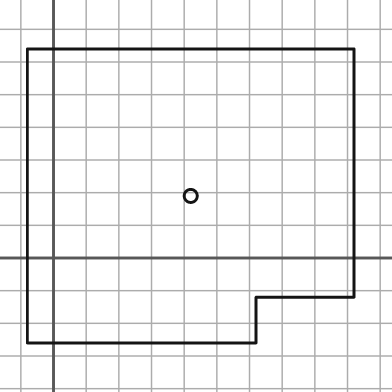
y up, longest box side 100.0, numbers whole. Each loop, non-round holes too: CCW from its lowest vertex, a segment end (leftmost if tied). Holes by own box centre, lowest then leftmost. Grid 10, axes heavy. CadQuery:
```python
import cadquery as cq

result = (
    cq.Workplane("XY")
    .moveTo(-8.0, -26.0)
    .lineTo(62.0, -26.0)
    .lineTo(62.0, -12.0)
    .lineTo(92.0, -12.0)
    .lineTo(92.0, 64.0)
    .lineTo(-8.0, 64.0)
    .close()
    .moveTo(42.0, 19.0)
    .circle(2.0)
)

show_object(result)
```